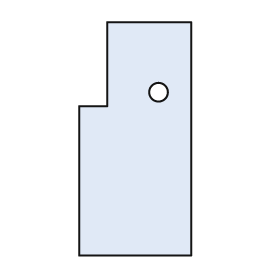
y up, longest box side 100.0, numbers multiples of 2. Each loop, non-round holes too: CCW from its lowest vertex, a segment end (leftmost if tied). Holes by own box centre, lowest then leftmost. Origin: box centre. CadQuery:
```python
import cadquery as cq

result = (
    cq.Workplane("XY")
    .moveTo(-24.0, -50.0)
    .lineTo(24.0, -50.0)
    .lineTo(24.0, 50.0)
    .lineTo(-12.0, 50.0)
    .lineTo(-12.0, 14.0)
    .lineTo(-24.0, 14.0)
    .close()
    .moveTo(10.0, 20.0)
    .circle(4.0)
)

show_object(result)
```